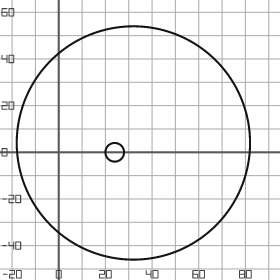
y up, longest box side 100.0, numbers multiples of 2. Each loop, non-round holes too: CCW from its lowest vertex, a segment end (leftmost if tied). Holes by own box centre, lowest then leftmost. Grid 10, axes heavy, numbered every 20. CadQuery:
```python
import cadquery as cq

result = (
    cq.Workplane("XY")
    .moveTo(32.0, 4.0)
    .circle(50.0)
    .moveTo(24.0, 0.0)
    .circle(4.0)
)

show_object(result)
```